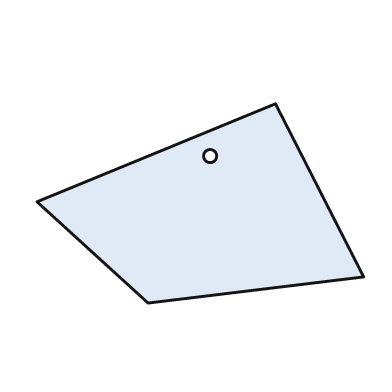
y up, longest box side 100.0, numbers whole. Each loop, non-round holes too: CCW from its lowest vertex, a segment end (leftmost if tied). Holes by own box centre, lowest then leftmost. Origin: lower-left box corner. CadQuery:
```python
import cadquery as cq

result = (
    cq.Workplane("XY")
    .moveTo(34.0, 0.0)
    .lineTo(100.0, 8.0)
    .lineTo(73.0, 61.0)
    .lineTo(0.0, 31.0)
    .close()
    .moveTo(53.0, 45.0)
    .circle(2.0)
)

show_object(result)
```